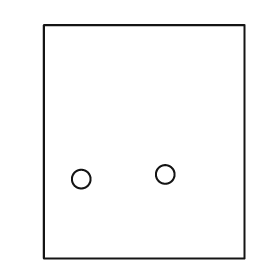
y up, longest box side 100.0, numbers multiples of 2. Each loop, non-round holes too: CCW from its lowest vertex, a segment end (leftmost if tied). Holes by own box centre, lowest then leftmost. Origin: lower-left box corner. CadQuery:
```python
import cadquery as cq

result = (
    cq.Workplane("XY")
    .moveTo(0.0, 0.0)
    .lineTo(86.0, 0.0)
    .lineTo(86.0, 100.0)
    .lineTo(0.0, 100.0)
    .close()
    .moveTo(16.0, 34.0)
    .circle(4.0)
    .moveTo(52.0, 36.0)
    .circle(4.0)
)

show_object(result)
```